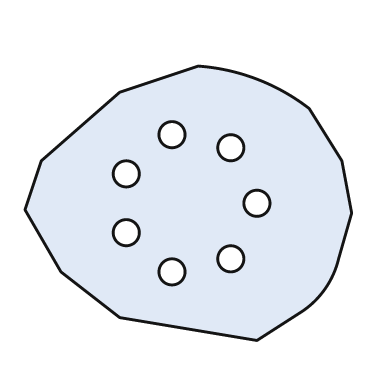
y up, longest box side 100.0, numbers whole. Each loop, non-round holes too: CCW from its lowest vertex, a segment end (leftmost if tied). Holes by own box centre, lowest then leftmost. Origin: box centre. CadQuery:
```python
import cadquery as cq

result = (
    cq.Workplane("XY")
    .moveTo(21.0, -42.0)
    .lineTo(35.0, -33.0)
    .threePointArc((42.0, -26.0), (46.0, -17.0))
    .lineTo(50.0, -3.0)
    .lineTo(47.0, 13.0)
    .lineTo(37.0, 29.0)
    .threePointArc((21.0, 38.0), (3.0, 42.0))
    .lineTo(-21.0, 34.0)
    .lineTo(-45.0, 13.0)
    .lineTo(-50.0, -2.0)
    .lineTo(-39.0, -21.0)
    .lineTo(-21.0, -35.0)
    .close()
    .moveTo(-5.0, -21.0)
    .circle(4.0)
    .moveTo(13.0, -17.0)
    .circle(4.0)
    .moveTo(-19.0, -9.0)
    .circle(4.0)
    .moveTo(21.0, 0.0)
    .circle(4.0)
    .moveTo(-19.0, 9.0)
    .circle(4.0)
    .moveTo(13.0, 17.0)
    .circle(4.0)
    .moveTo(-5.0, 21.0)
    .circle(4.0)
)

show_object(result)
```